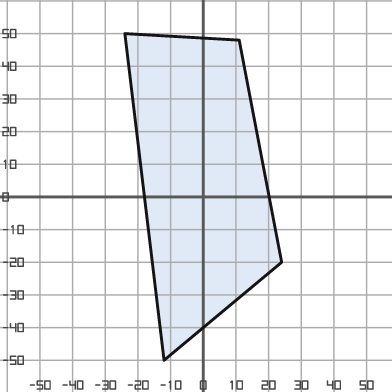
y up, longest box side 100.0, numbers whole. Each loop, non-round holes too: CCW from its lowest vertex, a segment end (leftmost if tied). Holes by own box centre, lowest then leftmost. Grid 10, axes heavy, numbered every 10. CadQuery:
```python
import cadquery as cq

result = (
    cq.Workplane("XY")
    .moveTo(-12.0, -50.0)
    .lineTo(24.0, -20.0)
    .lineTo(11.0, 48.0)
    .lineTo(-24.0, 50.0)
    .close()
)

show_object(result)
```